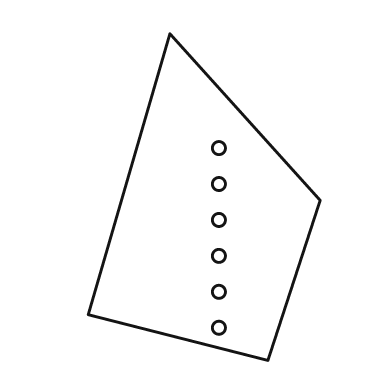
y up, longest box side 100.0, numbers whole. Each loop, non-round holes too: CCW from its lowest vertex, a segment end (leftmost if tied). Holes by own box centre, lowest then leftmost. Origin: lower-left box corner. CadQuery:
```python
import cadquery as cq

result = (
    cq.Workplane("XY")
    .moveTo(55.0, 0.0)
    .lineTo(71.0, 49.0)
    .lineTo(25.0, 100.0)
    .lineTo(0.0, 14.0)
    .close()
    .moveTo(40.0, 10.0)
    .circle(2.0)
    .moveTo(40.0, 21.0)
    .circle(2.0)
    .moveTo(40.0, 32.0)
    .circle(2.0)
    .moveTo(40.0, 43.0)
    .circle(2.0)
    .moveTo(40.0, 54.0)
    .circle(2.0)
    .moveTo(40.0, 65.0)
    .circle(2.0)
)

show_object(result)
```